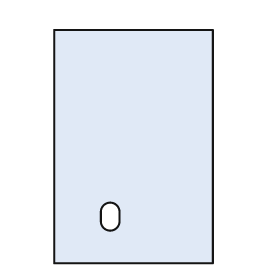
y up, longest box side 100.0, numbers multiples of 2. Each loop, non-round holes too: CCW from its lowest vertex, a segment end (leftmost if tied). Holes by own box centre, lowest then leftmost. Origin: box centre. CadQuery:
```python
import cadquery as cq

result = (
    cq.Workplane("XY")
    .moveTo(-34.0, -50.0)
    .lineTo(34.0, -50.0)
    .lineTo(34.0, 50.0)
    .lineTo(-34.0, 50.0)
    .close()
    .moveTo(-14.0, -32.0)
    .threePointArc((-10.0, -36.0), (-6.0, -32.0))
    .lineTo(-6.0, -28.0)
    .threePointArc((-10.0, -24.0), (-14.0, -28.0))
    .close()
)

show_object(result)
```